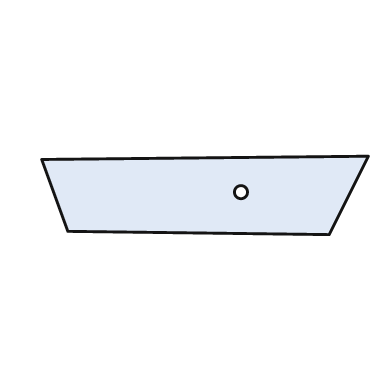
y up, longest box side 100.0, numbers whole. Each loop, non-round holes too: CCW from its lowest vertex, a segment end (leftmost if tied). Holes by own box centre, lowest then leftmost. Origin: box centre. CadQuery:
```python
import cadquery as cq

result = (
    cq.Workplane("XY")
    .moveTo(38.0, -12.0)
    .lineTo(50.0, 12.0)
    .lineTo(-50.0, 11.0)
    .lineTo(-42.0, -11.0)
    .close()
    .moveTo(11.0, 1.0)
    .circle(2.0)
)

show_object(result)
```